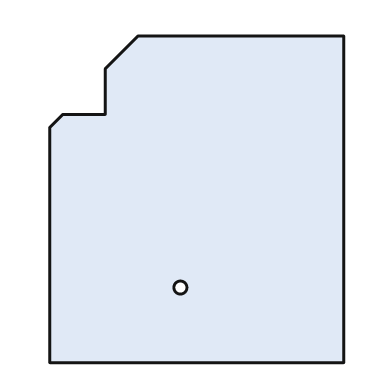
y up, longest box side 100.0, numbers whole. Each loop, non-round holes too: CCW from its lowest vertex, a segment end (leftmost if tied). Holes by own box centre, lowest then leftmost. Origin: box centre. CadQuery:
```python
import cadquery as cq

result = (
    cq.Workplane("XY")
    .moveTo(-45.0, -50.0)
    .lineTo(45.0, -50.0)
    .lineTo(45.0, 50.0)
    .lineTo(-18.0, 50.0)
    .lineTo(-28.0, 40.0)
    .lineTo(-28.0, 26.0)
    .lineTo(-41.0, 26.0)
    .lineTo(-45.0, 22.0)
    .close()
    .moveTo(-5.0, -27.0)
    .circle(2.0)
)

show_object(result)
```